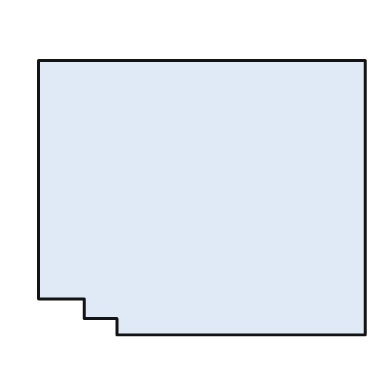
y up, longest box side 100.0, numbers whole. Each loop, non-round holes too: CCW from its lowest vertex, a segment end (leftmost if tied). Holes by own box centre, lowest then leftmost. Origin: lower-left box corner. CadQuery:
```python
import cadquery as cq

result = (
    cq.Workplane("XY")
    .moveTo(24.0, 0.0)
    .lineTo(100.0, 0.0)
    .lineTo(100.0, 84.0)
    .lineTo(0.0, 84.0)
    .lineTo(0.0, 11.0)
    .lineTo(14.0, 11.0)
    .lineTo(14.0, 5.0)
    .lineTo(24.0, 5.0)
    .close()
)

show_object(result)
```